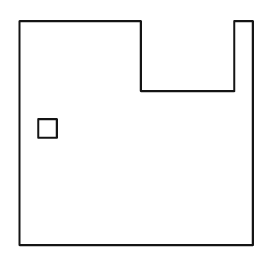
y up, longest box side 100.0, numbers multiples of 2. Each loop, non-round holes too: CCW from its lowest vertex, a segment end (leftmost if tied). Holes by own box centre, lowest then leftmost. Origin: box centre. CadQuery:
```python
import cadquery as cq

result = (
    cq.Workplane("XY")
    .moveTo(-50.0, -48.0)
    .lineTo(50.0, -48.0)
    .lineTo(50.0, 48.0)
    .lineTo(42.0, 48.0)
    .lineTo(42.0, 18.0)
    .lineTo(2.0, 18.0)
    .lineTo(2.0, 48.0)
    .lineTo(-50.0, 48.0)
    .close()
    .moveTo(-42.0, -2.0)
    .lineTo(-34.0, -2.0)
    .lineTo(-34.0, 6.0)
    .lineTo(-42.0, 6.0)
    .close()
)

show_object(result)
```